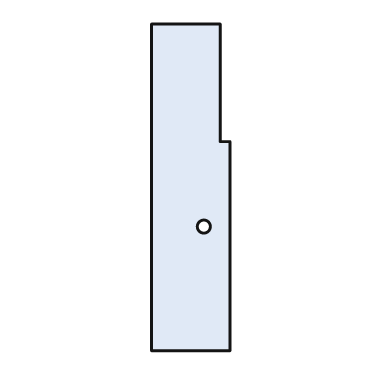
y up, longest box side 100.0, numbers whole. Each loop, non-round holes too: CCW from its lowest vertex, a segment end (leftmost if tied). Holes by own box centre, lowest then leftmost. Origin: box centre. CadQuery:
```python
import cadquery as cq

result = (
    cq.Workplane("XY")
    .moveTo(-12.0, -50.0)
    .lineTo(12.0, -50.0)
    .lineTo(12.0, 14.0)
    .lineTo(9.0, 14.0)
    .lineTo(9.0, 50.0)
    .lineTo(-12.0, 50.0)
    .close()
    .moveTo(4.0, -12.0)
    .circle(2.0)
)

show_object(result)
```